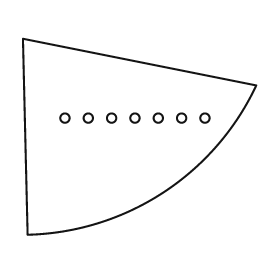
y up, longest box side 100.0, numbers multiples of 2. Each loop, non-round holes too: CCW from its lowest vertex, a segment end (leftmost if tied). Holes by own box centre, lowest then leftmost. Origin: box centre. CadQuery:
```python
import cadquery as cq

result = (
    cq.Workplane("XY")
    .moveTo(-48.0, -42.0)
    .threePointArc((10.0, -24.0), (50.0, 22.0))
    .lineTo(-50.0, 42.0)
    .close()
    .moveTo(-32.0, 8.0)
    .circle(2.0)
    .moveTo(-22.0, 8.0)
    .circle(2.0)
    .moveTo(-12.0, 8.0)
    .circle(2.0)
    .moveTo(-2.0, 8.0)
    .circle(2.0)
    .moveTo(8.0, 8.0)
    .circle(2.0)
    .moveTo(18.0, 8.0)
    .circle(2.0)
    .moveTo(28.0, 8.0)
    .circle(2.0)
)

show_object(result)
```